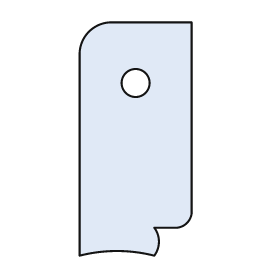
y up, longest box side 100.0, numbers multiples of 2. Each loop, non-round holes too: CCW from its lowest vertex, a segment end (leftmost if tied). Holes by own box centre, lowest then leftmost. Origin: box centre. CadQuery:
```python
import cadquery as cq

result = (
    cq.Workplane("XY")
    .moveTo(-24.0, -50.0)
    .threePointArc((-8.0, -48.0), (8.0, -50.0))
    .threePointArc((10.0, -44.0), (8.0, -38.0))
    .lineTo(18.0, -38.0)
    .threePointArc((22.0, -36.0), (24.0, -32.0))
    .lineTo(24.0, 50.0)
    .lineTo(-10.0, 50.0)
    .threePointArc((-20.0, 46.0), (-24.0, 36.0))
    .close()
    .moveTo(0.0, 24.0)
    .circle(6.0)
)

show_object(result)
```